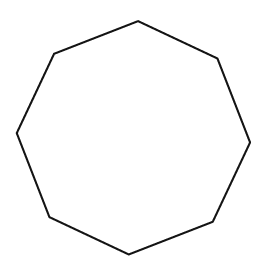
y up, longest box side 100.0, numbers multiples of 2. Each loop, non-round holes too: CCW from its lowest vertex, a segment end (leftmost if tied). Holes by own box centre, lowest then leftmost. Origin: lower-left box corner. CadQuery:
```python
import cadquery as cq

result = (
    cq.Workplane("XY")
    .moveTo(48.0, 0.0)
    .lineTo(84.0, 14.0)
    .lineTo(100.0, 48.0)
    .lineTo(86.0, 84.0)
    .lineTo(52.0, 100.0)
    .lineTo(16.0, 86.0)
    .lineTo(0.0, 52.0)
    .lineTo(14.0, 16.0)
    .close()
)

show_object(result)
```